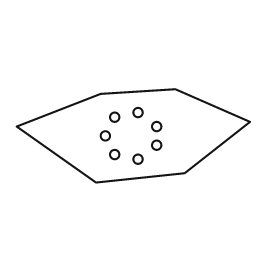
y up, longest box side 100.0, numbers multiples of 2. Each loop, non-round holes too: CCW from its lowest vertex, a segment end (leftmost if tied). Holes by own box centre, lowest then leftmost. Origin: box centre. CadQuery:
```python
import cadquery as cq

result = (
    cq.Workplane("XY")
    .moveTo(-16.0, -20.0)
    .lineTo(22.0, -16.0)
    .lineTo(50.0, 6.0)
    .lineTo(18.0, 20.0)
    .lineTo(-14.0, 18.0)
    .lineTo(-50.0, 4.0)
    .close()
    .moveTo(2.0, -10.0)
    .circle(2.0)
    .moveTo(-8.0, -8.0)
    .circle(2.0)
    .moveTo(10.0, -4.0)
    .circle(2.0)
    .moveTo(-12.0, 0.0)
    .circle(2.0)
    .moveTo(10.0, 4.0)
    .circle(2.0)
    .moveTo(-8.0, 8.0)
    .circle(2.0)
    .moveTo(2.0, 10.0)
    .circle(2.0)
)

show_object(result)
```